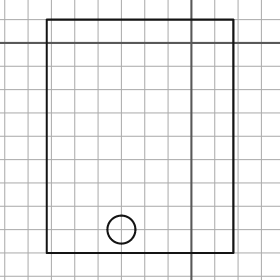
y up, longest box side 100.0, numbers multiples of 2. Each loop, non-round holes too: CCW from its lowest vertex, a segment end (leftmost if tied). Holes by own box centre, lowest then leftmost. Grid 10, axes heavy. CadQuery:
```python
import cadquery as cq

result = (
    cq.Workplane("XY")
    .moveTo(-62.0, -90.0)
    .lineTo(18.0, -90.0)
    .lineTo(18.0, 10.0)
    .lineTo(-62.0, 10.0)
    .close()
    .moveTo(-30.0, -80.0)
    .circle(6.0)
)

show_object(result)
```